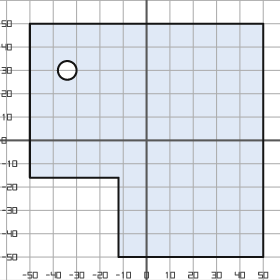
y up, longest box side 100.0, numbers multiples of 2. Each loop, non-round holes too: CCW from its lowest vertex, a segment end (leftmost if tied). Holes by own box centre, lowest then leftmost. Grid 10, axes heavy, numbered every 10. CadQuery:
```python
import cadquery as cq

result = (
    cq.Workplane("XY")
    .moveTo(-12.0, -50.0)
    .lineTo(50.0, -50.0)
    .lineTo(50.0, 50.0)
    .lineTo(-50.0, 50.0)
    .lineTo(-50.0, -16.0)
    .lineTo(-12.0, -16.0)
    .close()
    .moveTo(-34.0, 30.0)
    .circle(4.0)
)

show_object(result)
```